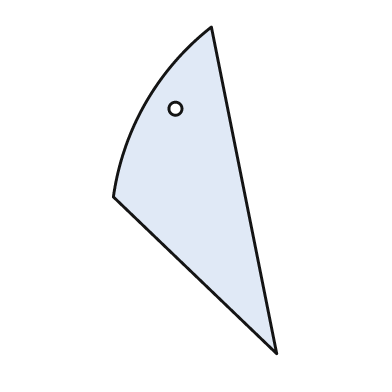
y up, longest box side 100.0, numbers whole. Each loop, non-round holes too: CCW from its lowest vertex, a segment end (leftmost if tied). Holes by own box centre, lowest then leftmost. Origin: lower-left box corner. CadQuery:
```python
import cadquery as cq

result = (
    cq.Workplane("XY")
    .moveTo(50.0, 0.0)
    .lineTo(30.0, 100.0)
    .threePointArc((10.0, 77.0), (0.0, 48.0))
    .close()
    .moveTo(19.0, 75.0)
    .circle(2.0)
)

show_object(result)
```